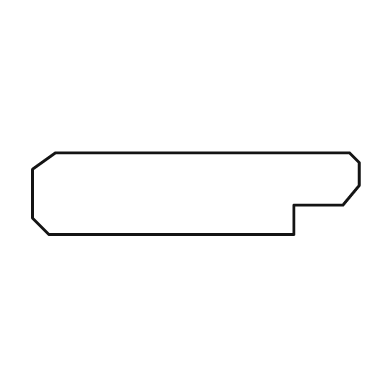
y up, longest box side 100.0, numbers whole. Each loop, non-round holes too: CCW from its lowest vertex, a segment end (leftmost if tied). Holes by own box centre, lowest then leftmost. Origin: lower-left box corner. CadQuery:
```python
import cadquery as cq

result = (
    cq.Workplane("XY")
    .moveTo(5.0, 0.0)
    .lineTo(80.0, 0.0)
    .lineTo(80.0, 9.0)
    .lineTo(95.0, 9.0)
    .lineTo(100.0, 15.0)
    .lineTo(100.0, 22.0)
    .lineTo(97.0, 25.0)
    .lineTo(7.0, 25.0)
    .lineTo(0.0, 20.0)
    .lineTo(0.0, 5.0)
    .close()
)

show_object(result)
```